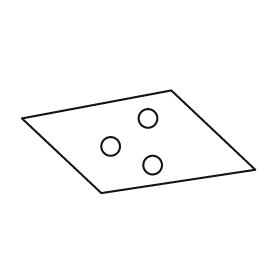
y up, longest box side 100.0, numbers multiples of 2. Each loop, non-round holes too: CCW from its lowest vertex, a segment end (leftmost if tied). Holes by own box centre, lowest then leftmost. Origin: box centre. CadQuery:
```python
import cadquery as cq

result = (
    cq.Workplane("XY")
    .moveTo(-16.0, -22.0)
    .lineTo(50.0, -12.0)
    .lineTo(14.0, 22.0)
    .lineTo(-50.0, 10.0)
    .close()
    .moveTo(6.0, -10.0)
    .circle(4.0)
    .moveTo(-12.0, -2.0)
    .circle(4.0)
    .moveTo(4.0, 10.0)
    .circle(4.0)
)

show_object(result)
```